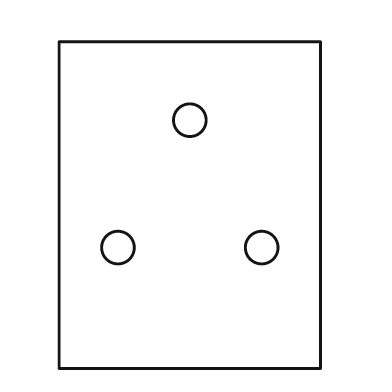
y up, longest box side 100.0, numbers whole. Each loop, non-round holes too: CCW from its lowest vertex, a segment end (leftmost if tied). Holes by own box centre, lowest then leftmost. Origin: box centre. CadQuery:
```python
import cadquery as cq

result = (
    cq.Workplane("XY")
    .moveTo(-40.0, -50.0)
    .lineTo(40.0, -50.0)
    .lineTo(40.0, 50.0)
    .lineTo(-40.0, 50.0)
    .close()
    .moveTo(-22.0, -13.0)
    .circle(5.0)
    .moveTo(22.0, -13.0)
    .circle(5.0)
    .moveTo(0.0, 26.0)
    .circle(5.0)
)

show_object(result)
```